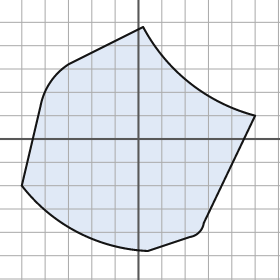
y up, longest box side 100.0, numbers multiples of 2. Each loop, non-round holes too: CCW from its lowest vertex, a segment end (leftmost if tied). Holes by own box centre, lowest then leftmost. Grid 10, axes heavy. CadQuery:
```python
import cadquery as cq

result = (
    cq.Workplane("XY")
    .moveTo(4.0, -48.0)
    .lineTo(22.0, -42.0)
    .threePointArc((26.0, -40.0), (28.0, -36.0))
    .lineTo(50.0, 10.0)
    .threePointArc((22.0, 24.0), (2.0, 48.0))
    .lineTo(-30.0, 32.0)
    .threePointArc((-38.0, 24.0), (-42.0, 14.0))
    .lineTo(-50.0, -20.0)
    .threePointArc((-26.0, -40.0), (4.0, -48.0))
    .close()
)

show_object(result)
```